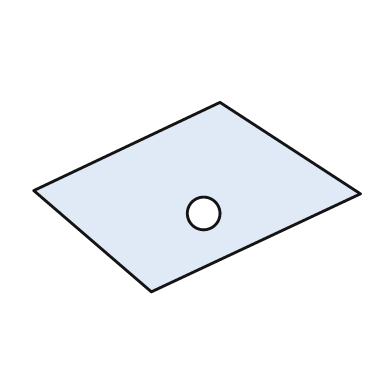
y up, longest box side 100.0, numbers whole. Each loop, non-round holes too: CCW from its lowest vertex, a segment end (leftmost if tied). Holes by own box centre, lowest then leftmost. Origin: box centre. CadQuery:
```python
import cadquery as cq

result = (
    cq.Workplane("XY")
    .moveTo(-14.0, -29.0)
    .lineTo(50.0, 1.0)
    .lineTo(7.0, 29.0)
    .lineTo(-50.0, 2.0)
    .close()
    .moveTo(2.0, -5.0)
    .circle(5.0)
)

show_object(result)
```